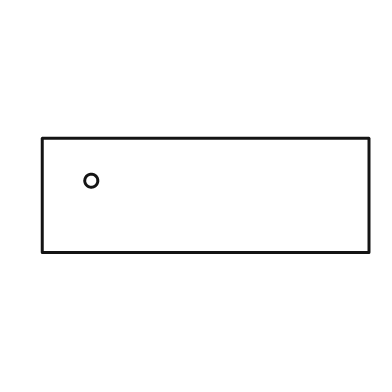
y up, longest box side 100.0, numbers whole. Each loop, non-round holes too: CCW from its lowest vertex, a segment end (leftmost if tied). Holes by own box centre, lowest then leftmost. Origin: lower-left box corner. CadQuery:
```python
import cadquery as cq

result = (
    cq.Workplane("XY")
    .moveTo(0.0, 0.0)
    .lineTo(100.0, 0.0)
    .lineTo(100.0, 35.0)
    .lineTo(0.0, 35.0)
    .close()
    .moveTo(15.0, 22.0)
    .circle(2.0)
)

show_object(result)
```